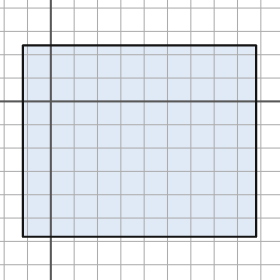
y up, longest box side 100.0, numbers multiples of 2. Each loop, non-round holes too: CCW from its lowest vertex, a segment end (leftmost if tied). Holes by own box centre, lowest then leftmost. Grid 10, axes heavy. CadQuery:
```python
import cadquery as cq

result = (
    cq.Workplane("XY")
    .moveTo(-12.0, -58.0)
    .lineTo(88.0, -58.0)
    .lineTo(88.0, 24.0)
    .lineTo(-12.0, 24.0)
    .close()
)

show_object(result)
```